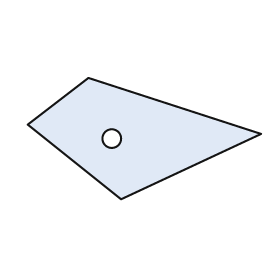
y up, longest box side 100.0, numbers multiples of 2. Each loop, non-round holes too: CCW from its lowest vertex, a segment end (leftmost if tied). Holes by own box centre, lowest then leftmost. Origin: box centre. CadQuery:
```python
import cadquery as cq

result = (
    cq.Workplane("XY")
    .moveTo(-10.0, -26.0)
    .lineTo(50.0, 2.0)
    .lineTo(-24.0, 26.0)
    .lineTo(-50.0, 6.0)
    .close()
    .moveTo(-14.0, 0.0)
    .circle(4.0)
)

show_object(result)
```